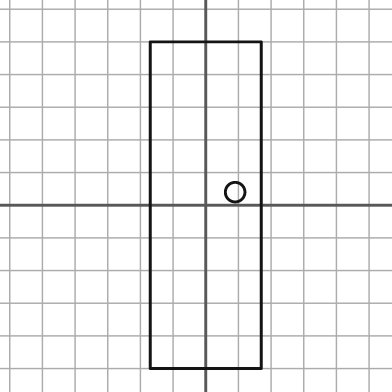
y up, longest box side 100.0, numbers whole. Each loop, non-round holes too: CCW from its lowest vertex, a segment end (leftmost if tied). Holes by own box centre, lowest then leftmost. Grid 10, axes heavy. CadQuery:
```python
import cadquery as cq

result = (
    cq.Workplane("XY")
    .moveTo(-17.0, -50.0)
    .lineTo(17.0, -50.0)
    .lineTo(17.0, 50.0)
    .lineTo(-17.0, 50.0)
    .close()
    .moveTo(9.0, 4.0)
    .circle(3.0)
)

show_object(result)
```